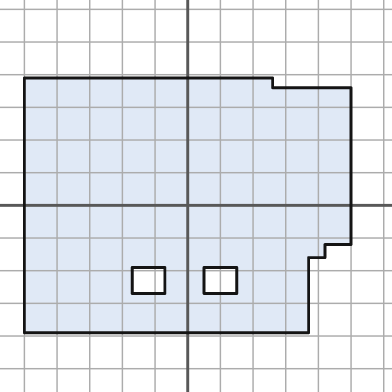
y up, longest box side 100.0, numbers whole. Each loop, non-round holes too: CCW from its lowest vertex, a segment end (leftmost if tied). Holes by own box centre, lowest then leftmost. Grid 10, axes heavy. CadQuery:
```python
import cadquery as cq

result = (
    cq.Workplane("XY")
    .moveTo(-50.0, -39.0)
    .lineTo(37.0, -39.0)
    .lineTo(37.0, -16.0)
    .lineTo(42.0, -16.0)
    .lineTo(42.0, -12.0)
    .lineTo(50.0, -12.0)
    .lineTo(50.0, 36.0)
    .lineTo(26.0, 36.0)
    .lineTo(26.0, 39.0)
    .lineTo(-50.0, 39.0)
    .close()
    .moveTo(-17.0, -27.0)
    .lineTo(-7.0, -27.0)
    .lineTo(-7.0, -19.0)
    .lineTo(-17.0, -19.0)
    .close()
    .moveTo(5.0, -27.0)
    .lineTo(15.0, -27.0)
    .lineTo(15.0, -19.0)
    .lineTo(5.0, -19.0)
    .close()
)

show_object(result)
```